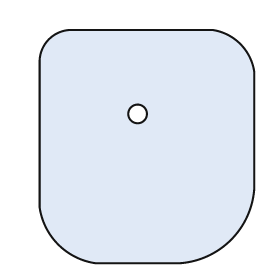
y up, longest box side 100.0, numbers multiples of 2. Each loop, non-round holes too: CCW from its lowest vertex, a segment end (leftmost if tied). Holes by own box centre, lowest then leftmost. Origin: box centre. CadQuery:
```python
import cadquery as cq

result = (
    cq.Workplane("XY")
    .moveTo(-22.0, -50.0)
    .lineTo(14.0, -50.0)
    .threePointArc((36.0, -40.0), (46.0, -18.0))
    .lineTo(46.0, 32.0)
    .threePointArc((40.0, 44.0), (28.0, 50.0))
    .lineTo(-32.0, 50.0)
    .threePointArc((-42.0, 46.0), (-46.0, 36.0))
    .lineTo(-46.0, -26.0)
    .threePointArc((-38.0, -42.0), (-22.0, -50.0))
    .close()
    .moveTo(-4.0, 14.0)
    .circle(4.0)
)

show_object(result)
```